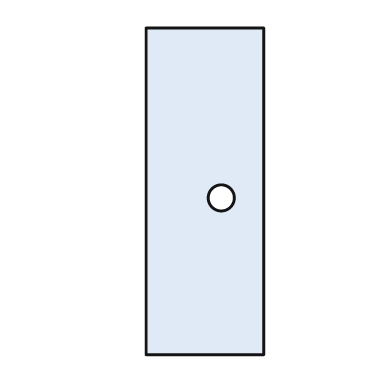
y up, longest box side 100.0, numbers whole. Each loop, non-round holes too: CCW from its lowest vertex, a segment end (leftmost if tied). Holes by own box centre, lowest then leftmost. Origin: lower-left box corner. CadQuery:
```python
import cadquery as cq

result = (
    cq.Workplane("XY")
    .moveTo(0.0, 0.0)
    .lineTo(36.0, 0.0)
    .lineTo(36.0, 100.0)
    .lineTo(0.0, 100.0)
    .close()
    .moveTo(23.0, 48.0)
    .circle(4.0)
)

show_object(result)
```